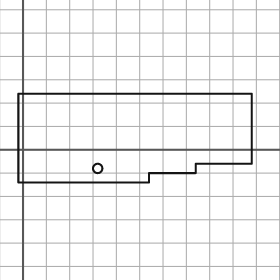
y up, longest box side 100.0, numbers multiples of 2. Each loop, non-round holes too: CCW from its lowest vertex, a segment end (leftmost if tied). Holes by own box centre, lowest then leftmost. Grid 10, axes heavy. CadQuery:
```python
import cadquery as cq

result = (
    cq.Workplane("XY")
    .moveTo(-2.0, -14.0)
    .lineTo(54.0, -14.0)
    .lineTo(54.0, -10.0)
    .lineTo(74.0, -10.0)
    .lineTo(74.0, -6.0)
    .lineTo(98.0, -6.0)
    .lineTo(98.0, 24.0)
    .lineTo(-2.0, 24.0)
    .close()
    .moveTo(32.0, -8.0)
    .circle(2.0)
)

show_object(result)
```